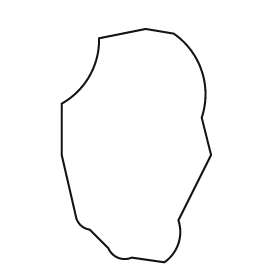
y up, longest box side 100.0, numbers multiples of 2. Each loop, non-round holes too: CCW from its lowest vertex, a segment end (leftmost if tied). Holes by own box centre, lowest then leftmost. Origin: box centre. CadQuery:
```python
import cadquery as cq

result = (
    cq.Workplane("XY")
    .moveTo(12.0, -50.0)
    .threePointArc((18.0, -42.0), (18.0, -32.0))
    .lineTo(32.0, -4.0)
    .lineTo(28.0, 12.0)
    .threePointArc((28.0, 32.0), (16.0, 48.0))
    .lineTo(4.0, 50.0)
    .lineTo(-16.0, 46.0)
    .threePointArc((-20.0, 30.0), (-32.0, 18.0))
    .lineTo(-32.0, -4.0)
    .lineTo(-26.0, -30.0)
    .threePointArc((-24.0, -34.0), (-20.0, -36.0))
    .lineTo(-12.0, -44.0)
    .threePointArc((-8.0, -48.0), (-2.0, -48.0))
    .close()
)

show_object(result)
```